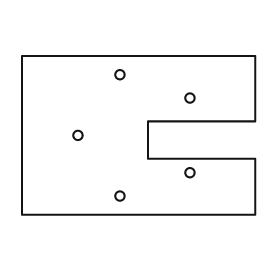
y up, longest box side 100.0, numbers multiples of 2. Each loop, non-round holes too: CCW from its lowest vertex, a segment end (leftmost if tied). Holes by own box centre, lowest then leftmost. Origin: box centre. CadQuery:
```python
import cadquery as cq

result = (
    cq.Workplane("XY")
    .moveTo(-50.0, -34.0)
    .lineTo(50.0, -34.0)
    .lineTo(50.0, -10.0)
    .lineTo(4.0, -10.0)
    .lineTo(4.0, 6.0)
    .lineTo(50.0, 6.0)
    .lineTo(50.0, 34.0)
    .lineTo(-50.0, 34.0)
    .close()
    .moveTo(-8.0, -26.0)
    .circle(2.0)
    .moveTo(22.0, -16.0)
    .circle(2.0)
    .moveTo(-26.0, 0.0)
    .circle(2.0)
    .moveTo(22.0, 16.0)
    .circle(2.0)
    .moveTo(-8.0, 26.0)
    .circle(2.0)
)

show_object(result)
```